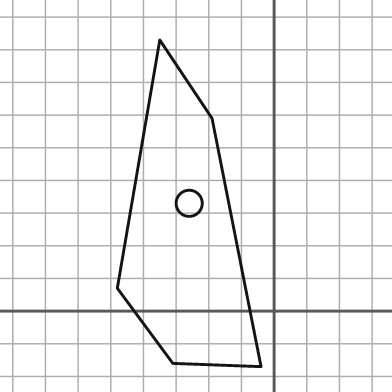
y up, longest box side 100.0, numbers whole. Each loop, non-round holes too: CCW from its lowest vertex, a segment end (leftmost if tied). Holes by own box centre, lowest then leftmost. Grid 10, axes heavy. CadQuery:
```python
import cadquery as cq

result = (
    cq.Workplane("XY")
    .moveTo(-4.0, -17.0)
    .lineTo(-19.0, 59.0)
    .lineTo(-35.0, 83.0)
    .lineTo(-48.0, 7.0)
    .lineTo(-31.0, -16.0)
    .close()
    .moveTo(-26.0, 33.0)
    .circle(4.0)
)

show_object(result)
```